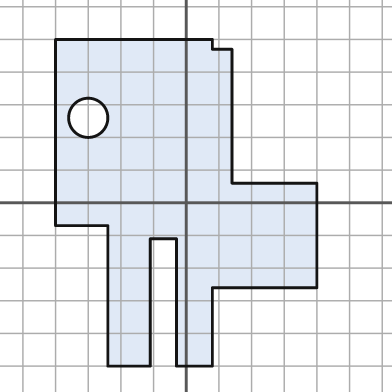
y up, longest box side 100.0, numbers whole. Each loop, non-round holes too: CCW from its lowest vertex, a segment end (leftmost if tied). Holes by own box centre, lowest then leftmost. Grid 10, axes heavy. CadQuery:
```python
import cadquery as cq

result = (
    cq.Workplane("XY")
    .moveTo(-24.0, -50.0)
    .lineTo(-11.0, -50.0)
    .lineTo(-11.0, -11.0)
    .lineTo(-3.0, -11.0)
    .lineTo(-3.0, -50.0)
    .lineTo(8.0, -50.0)
    .lineTo(8.0, -26.0)
    .lineTo(40.0, -26.0)
    .lineTo(40.0, 6.0)
    .lineTo(14.0, 6.0)
    .lineTo(14.0, 47.0)
    .lineTo(8.0, 47.0)
    .lineTo(8.0, 50.0)
    .lineTo(-40.0, 50.0)
    .lineTo(-40.0, -7.0)
    .lineTo(-24.0, -7.0)
    .close()
    .moveTo(-30.0, 26.0)
    .circle(6.0)
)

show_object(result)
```